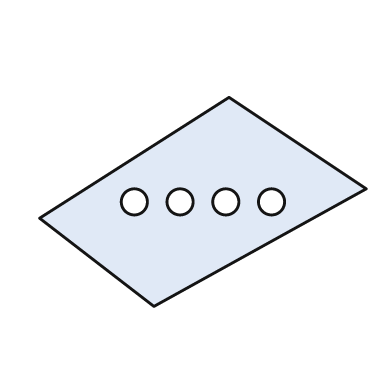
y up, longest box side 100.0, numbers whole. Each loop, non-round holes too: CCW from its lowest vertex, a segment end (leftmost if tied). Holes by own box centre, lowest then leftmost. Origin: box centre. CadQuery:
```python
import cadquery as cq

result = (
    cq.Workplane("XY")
    .moveTo(-15.0, -32.0)
    .lineTo(50.0, 4.0)
    .lineTo(8.0, 32.0)
    .lineTo(-50.0, -5.0)
    .close()
    .moveTo(-21.0, 0.0)
    .circle(4.0)
    .moveTo(-7.0, 0.0)
    .circle(4.0)
    .moveTo(7.0, 0.0)
    .circle(4.0)
    .moveTo(21.0, 0.0)
    .circle(4.0)
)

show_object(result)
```